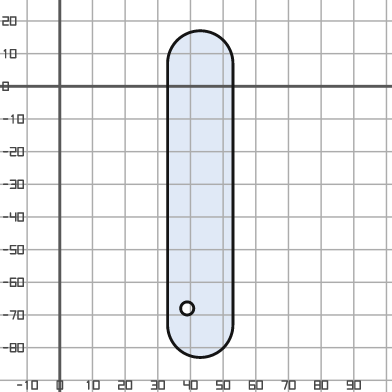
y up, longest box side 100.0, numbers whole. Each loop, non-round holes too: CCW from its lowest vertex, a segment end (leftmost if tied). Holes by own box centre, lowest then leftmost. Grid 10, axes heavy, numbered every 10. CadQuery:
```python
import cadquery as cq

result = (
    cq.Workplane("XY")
    .moveTo(33.0, -73.0)
    .threePointArc((43.0, -83.0), (53.0, -73.0))
    .lineTo(53.0, 7.0)
    .threePointArc((43.0, 17.0), (33.0, 7.0))
    .close()
    .moveTo(39.0, -68.0)
    .circle(2.0)
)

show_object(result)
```